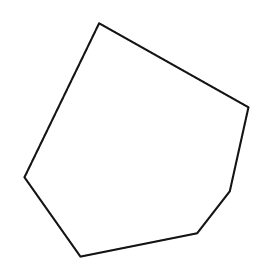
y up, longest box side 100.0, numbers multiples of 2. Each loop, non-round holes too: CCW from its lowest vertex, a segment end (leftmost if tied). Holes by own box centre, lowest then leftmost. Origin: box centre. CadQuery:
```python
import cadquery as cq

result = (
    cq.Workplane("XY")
    .moveTo(-24.0, -50.0)
    .lineTo(26.0, -40.0)
    .lineTo(40.0, -22.0)
    .lineTo(48.0, 14.0)
    .lineTo(-16.0, 50.0)
    .lineTo(-48.0, -16.0)
    .close()
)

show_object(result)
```